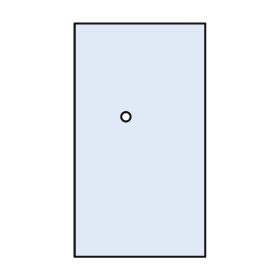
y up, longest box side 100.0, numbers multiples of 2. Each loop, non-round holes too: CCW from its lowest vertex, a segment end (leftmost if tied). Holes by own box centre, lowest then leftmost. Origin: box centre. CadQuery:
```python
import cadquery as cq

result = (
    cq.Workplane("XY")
    .moveTo(-28.0, -50.0)
    .lineTo(28.0, -50.0)
    .lineTo(28.0, 50.0)
    .lineTo(-28.0, 50.0)
    .close()
    .moveTo(-6.0, 10.0)
    .circle(2.0)
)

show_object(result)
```